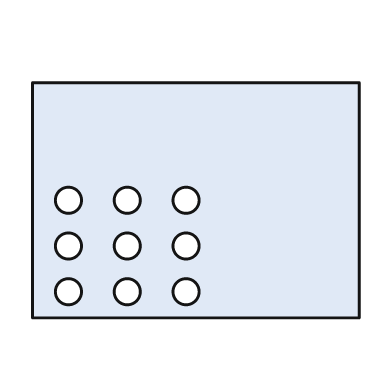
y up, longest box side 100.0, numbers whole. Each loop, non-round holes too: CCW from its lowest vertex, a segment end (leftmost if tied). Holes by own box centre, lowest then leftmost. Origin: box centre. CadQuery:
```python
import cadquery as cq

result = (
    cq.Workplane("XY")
    .moveTo(-50.0, -36.0)
    .lineTo(50.0, -36.0)
    .lineTo(50.0, 36.0)
    .lineTo(-50.0, 36.0)
    .close()
    .moveTo(-39.0, -28.0)
    .circle(4.0)
    .moveTo(-21.0, -28.0)
    .circle(4.0)
    .moveTo(-3.0, -28.0)
    .circle(4.0)
    .moveTo(-39.0, -14.0)
    .circle(4.0)
    .moveTo(-21.0, -14.0)
    .circle(4.0)
    .moveTo(-3.0, -14.0)
    .circle(4.0)
    .moveTo(-39.0, 0.0)
    .circle(4.0)
    .moveTo(-21.0, 0.0)
    .circle(4.0)
    .moveTo(-3.0, 0.0)
    .circle(4.0)
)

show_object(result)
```